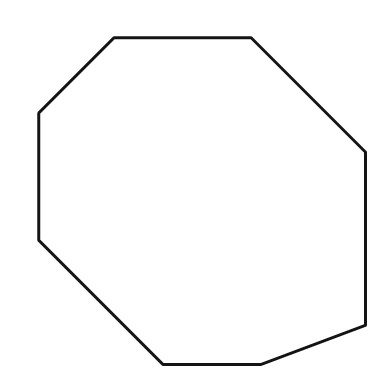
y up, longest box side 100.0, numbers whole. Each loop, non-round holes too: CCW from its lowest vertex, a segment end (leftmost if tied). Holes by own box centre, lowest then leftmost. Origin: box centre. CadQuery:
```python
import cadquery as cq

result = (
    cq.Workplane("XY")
    .moveTo(-12.0, -50.0)
    .lineTo(18.0, -50.0)
    .lineTo(50.0, -38.0)
    .lineTo(50.0, 15.0)
    .lineTo(15.0, 50.0)
    .lineTo(-27.0, 50.0)
    .lineTo(-50.0, 27.0)
    .lineTo(-50.0, -12.0)
    .close()
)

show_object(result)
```